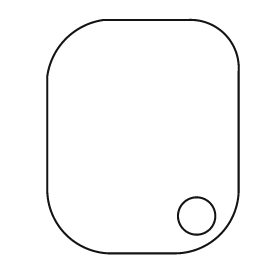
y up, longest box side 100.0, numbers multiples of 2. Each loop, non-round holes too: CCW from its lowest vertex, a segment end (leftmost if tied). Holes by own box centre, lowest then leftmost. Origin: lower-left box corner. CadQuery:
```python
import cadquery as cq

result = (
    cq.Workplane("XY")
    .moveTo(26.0, 0.0)
    .lineTo(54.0, 0.0)
    .threePointArc((74.0, 8.0), (82.0, 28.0))
    .lineTo(82.0, 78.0)
    .threePointArc((76.0, 94.0), (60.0, 100.0))
    .lineTo(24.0, 100.0)
    .threePointArc((8.0, 92.0), (0.0, 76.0))
    .lineTo(0.0, 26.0)
    .threePointArc((8.0, 8.0), (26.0, 0.0))
    .close()
    .moveTo(64.0, 16.0)
    .circle(8.0)
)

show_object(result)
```